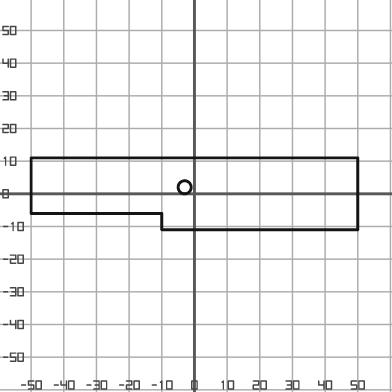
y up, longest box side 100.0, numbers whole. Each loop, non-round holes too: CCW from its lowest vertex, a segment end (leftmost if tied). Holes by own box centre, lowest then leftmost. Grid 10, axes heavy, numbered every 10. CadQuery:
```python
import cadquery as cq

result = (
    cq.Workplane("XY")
    .moveTo(-10.0, -11.0)
    .lineTo(50.0, -11.0)
    .lineTo(50.0, 11.0)
    .lineTo(-50.0, 11.0)
    .lineTo(-50.0, -6.0)
    .lineTo(-10.0, -6.0)
    .close()
    .moveTo(-3.0, 2.0)
    .circle(2.0)
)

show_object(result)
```